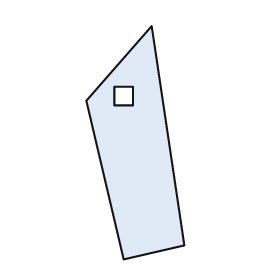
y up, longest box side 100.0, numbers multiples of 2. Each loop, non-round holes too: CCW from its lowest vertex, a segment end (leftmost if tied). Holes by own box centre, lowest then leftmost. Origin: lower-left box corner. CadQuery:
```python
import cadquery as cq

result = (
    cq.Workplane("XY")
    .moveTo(16.0, 0.0)
    .lineTo(42.0, 6.0)
    .lineTo(28.0, 100.0)
    .lineTo(0.0, 68.0)
    .close()
    .moveTo(12.0, 66.0)
    .lineTo(20.0, 66.0)
    .lineTo(20.0, 74.0)
    .lineTo(12.0, 74.0)
    .close()
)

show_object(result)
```